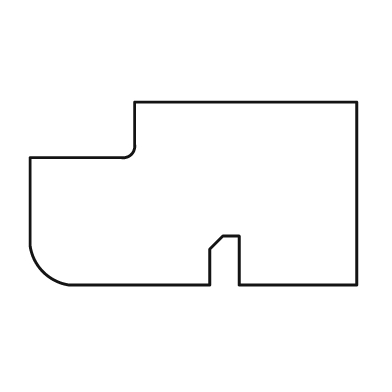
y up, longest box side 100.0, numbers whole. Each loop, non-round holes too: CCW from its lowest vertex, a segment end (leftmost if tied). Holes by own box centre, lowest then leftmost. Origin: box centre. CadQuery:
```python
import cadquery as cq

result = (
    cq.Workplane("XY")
    .moveTo(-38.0, -28.0)
    .lineTo(5.0, -28.0)
    .lineTo(5.0, -17.0)
    .lineTo(9.0, -13.0)
    .lineTo(14.0, -13.0)
    .lineTo(14.0, -28.0)
    .lineTo(50.0, -28.0)
    .lineTo(50.0, 28.0)
    .lineTo(-18.0, 28.0)
    .lineTo(-18.0, 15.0)
    .threePointArc((-19.0, 12.0), (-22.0, 11.0))
    .lineTo(-50.0, 11.0)
    .lineTo(-50.0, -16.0)
    .threePointArc((-46.0, -24.0), (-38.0, -28.0))
    .close()
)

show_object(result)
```